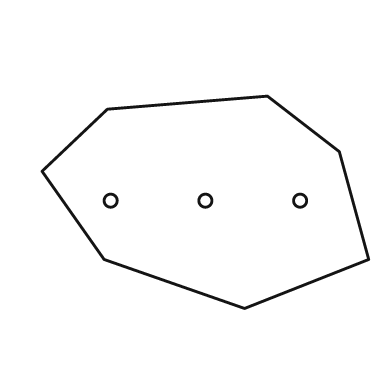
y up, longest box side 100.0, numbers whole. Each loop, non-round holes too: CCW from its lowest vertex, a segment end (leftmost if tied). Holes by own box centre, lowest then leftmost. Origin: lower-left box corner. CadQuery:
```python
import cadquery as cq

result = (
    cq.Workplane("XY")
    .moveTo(62.0, 0.0)
    .lineTo(100.0, 15.0)
    .lineTo(91.0, 48.0)
    .lineTo(69.0, 65.0)
    .lineTo(20.0, 61.0)
    .lineTo(0.0, 42.0)
    .lineTo(19.0, 15.0)
    .close()
    .moveTo(21.0, 33.0)
    .circle(2.0)
    .moveTo(50.0, 33.0)
    .circle(2.0)
    .moveTo(79.0, 33.0)
    .circle(2.0)
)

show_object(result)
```